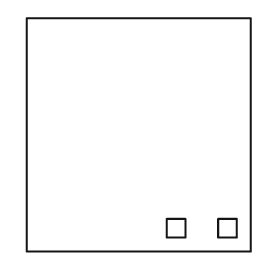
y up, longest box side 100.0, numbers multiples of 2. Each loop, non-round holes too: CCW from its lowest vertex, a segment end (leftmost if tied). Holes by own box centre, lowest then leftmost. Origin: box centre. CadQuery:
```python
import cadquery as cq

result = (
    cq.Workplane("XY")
    .moveTo(-48.0, -50.0)
    .lineTo(48.0, -50.0)
    .lineTo(48.0, 50.0)
    .lineTo(-48.0, 50.0)
    .close()
    .moveTo(12.0, -44.0)
    .lineTo(20.0, -44.0)
    .lineTo(20.0, -36.0)
    .lineTo(12.0, -36.0)
    .close()
    .moveTo(34.0, -44.0)
    .lineTo(42.0, -44.0)
    .lineTo(42.0, -36.0)
    .lineTo(34.0, -36.0)
    .close()
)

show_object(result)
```